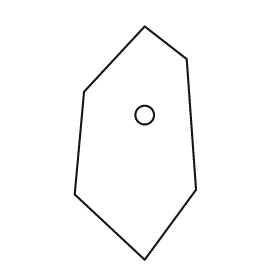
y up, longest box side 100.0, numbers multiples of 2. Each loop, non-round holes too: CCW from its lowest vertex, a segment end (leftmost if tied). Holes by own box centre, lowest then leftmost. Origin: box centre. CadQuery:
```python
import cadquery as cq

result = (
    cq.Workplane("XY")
    .moveTo(4.0, -50.0)
    .lineTo(26.0, -20.0)
    .lineTo(22.0, 36.0)
    .lineTo(4.0, 50.0)
    .lineTo(-22.0, 22.0)
    .lineTo(-26.0, -22.0)
    .close()
    .moveTo(4.0, 12.0)
    .circle(4.0)
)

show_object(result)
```